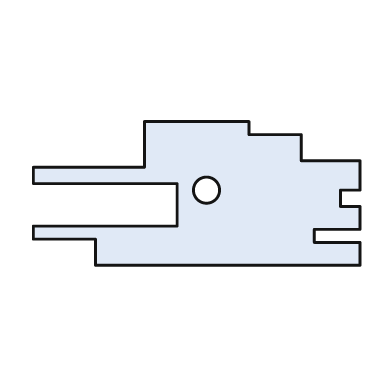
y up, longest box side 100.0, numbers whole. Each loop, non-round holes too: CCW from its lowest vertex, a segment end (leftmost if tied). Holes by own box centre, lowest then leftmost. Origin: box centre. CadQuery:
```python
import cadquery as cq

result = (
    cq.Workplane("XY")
    .moveTo(-31.0, -22.0)
    .lineTo(50.0, -22.0)
    .lineTo(50.0, -15.0)
    .lineTo(36.0, -15.0)
    .lineTo(36.0, -11.0)
    .lineTo(50.0, -11.0)
    .lineTo(50.0, -4.0)
    .lineTo(44.0, -4.0)
    .lineTo(44.0, 1.0)
    .lineTo(50.0, 1.0)
    .lineTo(50.0, 10.0)
    .lineTo(32.0, 10.0)
    .lineTo(32.0, 18.0)
    .lineTo(16.0, 18.0)
    .lineTo(16.0, 22.0)
    .lineTo(-16.0, 22.0)
    .lineTo(-16.0, 8.0)
    .lineTo(-50.0, 8.0)
    .lineTo(-50.0, 3.0)
    .lineTo(-6.0, 3.0)
    .lineTo(-6.0, -10.0)
    .lineTo(-50.0, -10.0)
    .lineTo(-50.0, -14.0)
    .lineTo(-31.0, -14.0)
    .close()
    .moveTo(3.0, 1.0)
    .circle(4.0)
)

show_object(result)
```